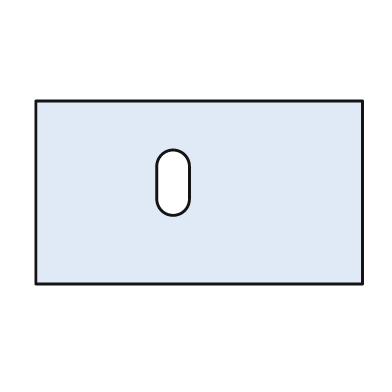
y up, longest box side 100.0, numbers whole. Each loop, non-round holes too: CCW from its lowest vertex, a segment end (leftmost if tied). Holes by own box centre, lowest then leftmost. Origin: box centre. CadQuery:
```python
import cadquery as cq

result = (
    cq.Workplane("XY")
    .moveTo(-50.0, -28.0)
    .lineTo(50.0, -28.0)
    .lineTo(50.0, 28.0)
    .lineTo(-50.0, 28.0)
    .close()
    .moveTo(-13.0, -2.0)
    .threePointArc((-8.0, -7.0), (-3.0, -2.0))
    .lineTo(-3.0, 8.0)
    .threePointArc((-8.0, 13.0), (-13.0, 8.0))
    .close()
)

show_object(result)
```